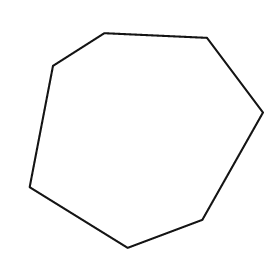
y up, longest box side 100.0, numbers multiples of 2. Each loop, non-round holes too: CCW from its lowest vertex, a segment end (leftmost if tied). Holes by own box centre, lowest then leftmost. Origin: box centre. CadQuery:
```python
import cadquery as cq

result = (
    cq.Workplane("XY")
    .moveTo(-8.0, -46.0)
    .lineTo(24.0, -34.0)
    .lineTo(50.0, 12.0)
    .lineTo(26.0, 44.0)
    .lineTo(-18.0, 46.0)
    .lineTo(-40.0, 32.0)
    .lineTo(-50.0, -20.0)
    .close()
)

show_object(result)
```